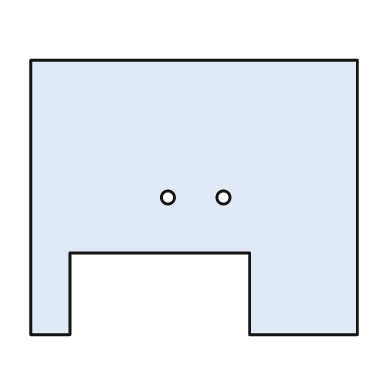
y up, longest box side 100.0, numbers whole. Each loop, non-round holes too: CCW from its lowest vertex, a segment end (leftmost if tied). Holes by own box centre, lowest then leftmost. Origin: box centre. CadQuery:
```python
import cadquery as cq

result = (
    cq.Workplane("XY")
    .moveTo(-50.0, -42.0)
    .lineTo(-38.0, -42.0)
    .lineTo(-38.0, -17.0)
    .lineTo(17.0, -17.0)
    .lineTo(17.0, -42.0)
    .lineTo(50.0, -42.0)
    .lineTo(50.0, 42.0)
    .lineTo(-50.0, 42.0)
    .close()
    .moveTo(-8.0, 0.0)
    .circle(2.0)
    .moveTo(9.0, 0.0)
    .circle(2.0)
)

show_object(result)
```